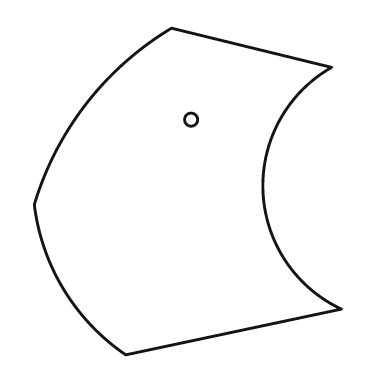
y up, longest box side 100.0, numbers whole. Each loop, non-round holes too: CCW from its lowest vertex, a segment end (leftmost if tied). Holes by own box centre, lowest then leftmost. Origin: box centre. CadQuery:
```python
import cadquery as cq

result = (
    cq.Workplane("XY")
    .moveTo(-19.0, -50.0)
    .lineTo(47.0, -36.0)
    .threePointArc((23.0, 0.0), (44.0, 38.0))
    .lineTo(-5.0, 50.0)
    .threePointArc((-31.0, 27.0), (-47.0, -4.0))
    .threePointArc((-38.0, -30.0), (-19.0, -50.0))
    .close()
    .moveTo(1.0, 22.0)
    .circle(2.0)
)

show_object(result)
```